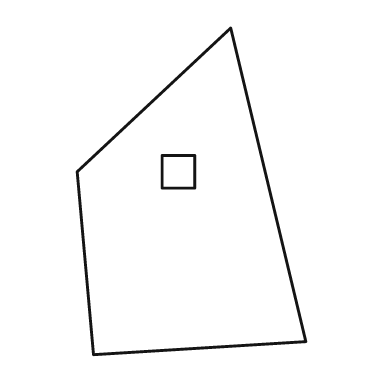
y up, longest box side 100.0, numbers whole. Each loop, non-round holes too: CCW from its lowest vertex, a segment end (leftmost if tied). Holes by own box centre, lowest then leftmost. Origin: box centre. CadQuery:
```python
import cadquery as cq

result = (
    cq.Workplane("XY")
    .moveTo(-30.0, -50.0)
    .lineTo(35.0, -46.0)
    .lineTo(12.0, 50.0)
    .lineTo(-35.0, 6.0)
    .close()
    .moveTo(-9.0, 1.0)
    .lineTo(1.0, 1.0)
    .lineTo(1.0, 11.0)
    .lineTo(-9.0, 11.0)
    .close()
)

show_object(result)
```